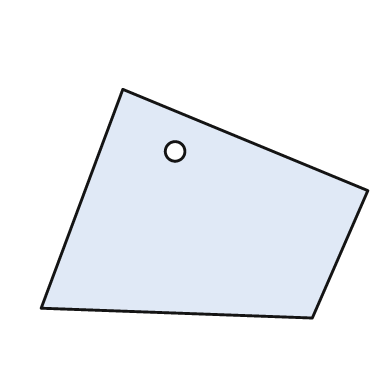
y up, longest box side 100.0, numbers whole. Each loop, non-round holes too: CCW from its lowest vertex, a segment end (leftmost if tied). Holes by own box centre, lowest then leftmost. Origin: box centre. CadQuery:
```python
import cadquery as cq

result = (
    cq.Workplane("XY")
    .moveTo(33.0, -35.0)
    .lineTo(50.0, 4.0)
    .lineTo(-25.0, 35.0)
    .lineTo(-50.0, -32.0)
    .close()
    .moveTo(-9.0, 16.0)
    .circle(3.0)
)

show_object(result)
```